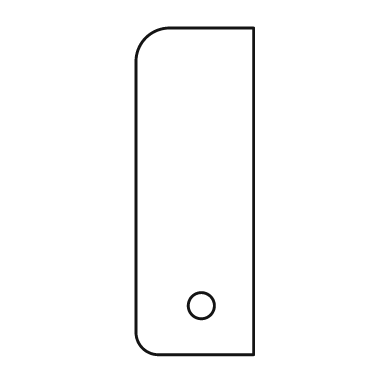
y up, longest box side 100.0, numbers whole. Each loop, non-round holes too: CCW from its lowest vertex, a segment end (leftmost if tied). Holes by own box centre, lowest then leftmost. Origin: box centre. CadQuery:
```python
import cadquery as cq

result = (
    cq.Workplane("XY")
    .moveTo(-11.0, -50.0)
    .lineTo(18.0, -50.0)
    .lineTo(18.0, 50.0)
    .lineTo(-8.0, 50.0)
    .threePointArc((-15.0, 47.0), (-18.0, 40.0))
    .lineTo(-18.0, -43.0)
    .threePointArc((-16.0, -48.0), (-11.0, -50.0))
    .close()
    .moveTo(2.0, -35.0)
    .circle(4.0)
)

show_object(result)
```